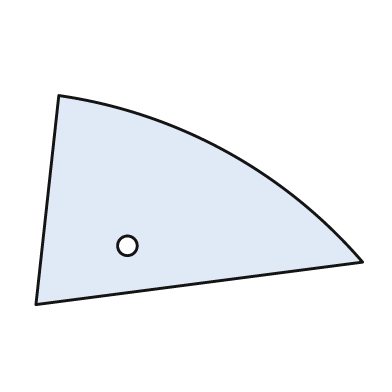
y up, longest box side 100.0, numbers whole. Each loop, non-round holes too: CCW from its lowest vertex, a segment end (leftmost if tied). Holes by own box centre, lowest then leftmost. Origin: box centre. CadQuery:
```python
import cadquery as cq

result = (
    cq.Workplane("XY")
    .moveTo(-50.0, -32.0)
    .lineTo(50.0, -19.0)
    .threePointArc((8.0, 15.0), (-43.0, 32.0))
    .close()
    .moveTo(-22.0, -14.0)
    .circle(3.0)
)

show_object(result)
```